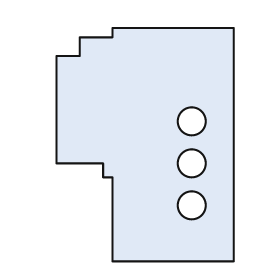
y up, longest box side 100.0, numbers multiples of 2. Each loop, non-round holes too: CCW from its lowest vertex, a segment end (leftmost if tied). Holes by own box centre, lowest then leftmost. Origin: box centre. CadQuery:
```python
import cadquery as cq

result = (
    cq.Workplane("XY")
    .moveTo(-14.0, -50.0)
    .lineTo(38.0, -50.0)
    .lineTo(38.0, 50.0)
    .lineTo(-14.0, 50.0)
    .lineTo(-14.0, 46.0)
    .lineTo(-28.0, 46.0)
    .lineTo(-28.0, 38.0)
    .lineTo(-38.0, 38.0)
    .lineTo(-38.0, -8.0)
    .lineTo(-18.0, -8.0)
    .lineTo(-18.0, -14.0)
    .lineTo(-14.0, -14.0)
    .close()
    .moveTo(20.0, -26.0)
    .circle(6.0)
    .moveTo(20.0, -8.0)
    .circle(6.0)
    .moveTo(20.0, 10.0)
    .circle(6.0)
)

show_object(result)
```